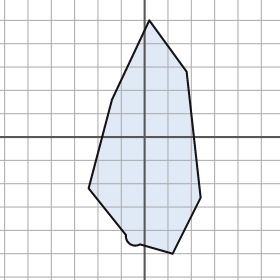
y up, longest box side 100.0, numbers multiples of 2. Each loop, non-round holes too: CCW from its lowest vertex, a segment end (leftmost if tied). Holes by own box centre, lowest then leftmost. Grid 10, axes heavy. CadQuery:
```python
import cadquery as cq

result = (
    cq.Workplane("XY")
    .moveTo(12.0, -50.0)
    .lineTo(24.0, -26.0)
    .lineTo(18.0, 28.0)
    .lineTo(2.0, 50.0)
    .lineTo(-14.0, 16.0)
    .lineTo(-24.0, -22.0)
    .lineTo(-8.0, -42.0)
    .threePointArc((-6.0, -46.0), (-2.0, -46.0))
    .close()
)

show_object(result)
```